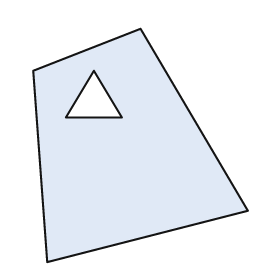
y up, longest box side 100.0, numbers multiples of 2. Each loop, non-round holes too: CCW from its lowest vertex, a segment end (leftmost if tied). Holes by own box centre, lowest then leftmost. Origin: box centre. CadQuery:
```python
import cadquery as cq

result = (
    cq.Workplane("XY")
    .moveTo(-40.0, -50.0)
    .lineTo(46.0, -28.0)
    .lineTo(0.0, 50.0)
    .lineTo(-46.0, 32.0)
    .close()
    .moveTo(-32.0, 12.0)
    .lineTo(-8.0, 12.0)
    .lineTo(-20.0, 32.0)
    .close()
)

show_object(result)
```